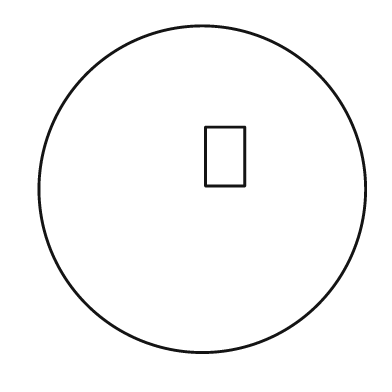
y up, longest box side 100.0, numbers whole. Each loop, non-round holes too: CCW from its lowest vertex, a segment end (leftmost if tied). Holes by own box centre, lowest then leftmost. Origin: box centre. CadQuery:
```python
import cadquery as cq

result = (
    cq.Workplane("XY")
    .moveTo(0.0, 0.0)
    .circle(50.0)
    .moveTo(1.0, 1.0)
    .lineTo(13.0, 1.0)
    .lineTo(13.0, 19.0)
    .lineTo(1.0, 19.0)
    .close()
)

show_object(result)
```